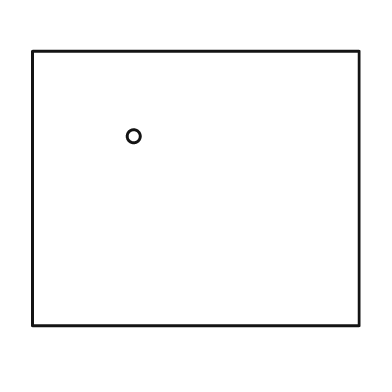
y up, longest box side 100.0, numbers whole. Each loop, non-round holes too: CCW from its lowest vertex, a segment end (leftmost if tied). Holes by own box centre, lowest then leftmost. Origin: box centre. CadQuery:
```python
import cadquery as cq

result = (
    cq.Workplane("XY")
    .moveTo(-50.0, -42.0)
    .lineTo(50.0, -42.0)
    .lineTo(50.0, 42.0)
    .lineTo(-50.0, 42.0)
    .close()
    .moveTo(-19.0, 16.0)
    .circle(2.0)
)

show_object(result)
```